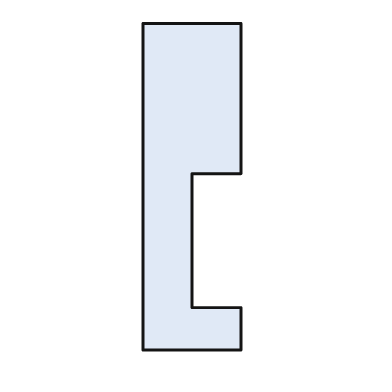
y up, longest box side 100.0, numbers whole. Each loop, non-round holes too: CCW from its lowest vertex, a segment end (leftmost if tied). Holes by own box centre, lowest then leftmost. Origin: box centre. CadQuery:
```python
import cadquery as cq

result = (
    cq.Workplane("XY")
    .moveTo(-15.0, -50.0)
    .lineTo(15.0, -50.0)
    .lineTo(15.0, -37.0)
    .lineTo(0.0, -37.0)
    .lineTo(0.0, 4.0)
    .lineTo(15.0, 4.0)
    .lineTo(15.0, 50.0)
    .lineTo(-15.0, 50.0)
    .close()
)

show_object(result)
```